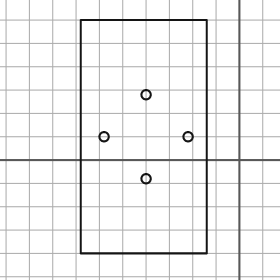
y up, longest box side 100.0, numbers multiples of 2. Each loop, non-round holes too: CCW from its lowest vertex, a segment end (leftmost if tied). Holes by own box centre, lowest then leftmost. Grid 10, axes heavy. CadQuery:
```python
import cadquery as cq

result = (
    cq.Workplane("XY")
    .moveTo(-68.0, -40.0)
    .lineTo(-14.0, -40.0)
    .lineTo(-14.0, 60.0)
    .lineTo(-68.0, 60.0)
    .close()
    .moveTo(-40.0, -8.0)
    .circle(2.0)
    .moveTo(-58.0, 10.0)
    .circle(2.0)
    .moveTo(-22.0, 10.0)
    .circle(2.0)
    .moveTo(-40.0, 28.0)
    .circle(2.0)
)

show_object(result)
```